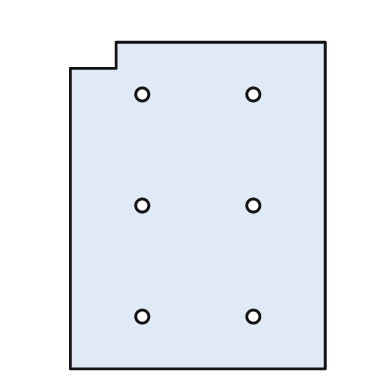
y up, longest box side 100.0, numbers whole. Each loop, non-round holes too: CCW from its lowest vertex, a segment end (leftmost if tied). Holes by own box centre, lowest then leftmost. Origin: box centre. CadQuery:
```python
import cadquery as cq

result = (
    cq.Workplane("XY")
    .moveTo(-39.0, -50.0)
    .lineTo(39.0, -50.0)
    .lineTo(39.0, 50.0)
    .lineTo(-25.0, 50.0)
    .lineTo(-25.0, 42.0)
    .lineTo(-39.0, 42.0)
    .close()
    .moveTo(-17.0, -34.0)
    .circle(2.0)
    .moveTo(17.0, -34.0)
    .circle(2.0)
    .moveTo(-17.0, 0.0)
    .circle(2.0)
    .moveTo(17.0, 0.0)
    .circle(2.0)
    .moveTo(-17.0, 34.0)
    .circle(2.0)
    .moveTo(17.0, 34.0)
    .circle(2.0)
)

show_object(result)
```